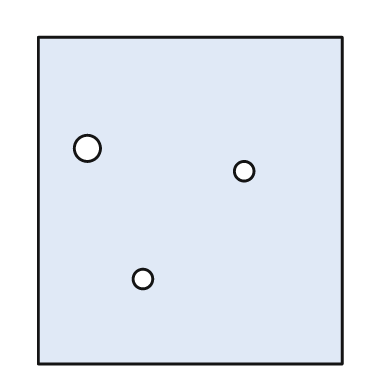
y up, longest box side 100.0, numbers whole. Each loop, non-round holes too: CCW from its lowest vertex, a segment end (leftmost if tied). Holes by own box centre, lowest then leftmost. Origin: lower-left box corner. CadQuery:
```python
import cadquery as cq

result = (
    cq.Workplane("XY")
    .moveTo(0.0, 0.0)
    .lineTo(93.0, 0.0)
    .lineTo(93.0, 100.0)
    .lineTo(0.0, 100.0)
    .close()
    .moveTo(32.0, 26.0)
    .circle(3.0)
    .moveTo(63.0, 59.0)
    .circle(3.0)
    .moveTo(15.0, 66.0)
    .circle(4.0)
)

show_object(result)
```